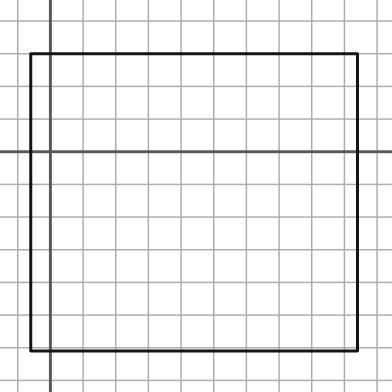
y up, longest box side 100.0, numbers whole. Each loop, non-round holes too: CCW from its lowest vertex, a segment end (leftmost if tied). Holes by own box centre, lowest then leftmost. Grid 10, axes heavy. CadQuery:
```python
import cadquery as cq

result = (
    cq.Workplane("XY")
    .moveTo(-6.0, -61.0)
    .lineTo(94.0, -61.0)
    .lineTo(94.0, 30.0)
    .lineTo(-6.0, 30.0)
    .close()
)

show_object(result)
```